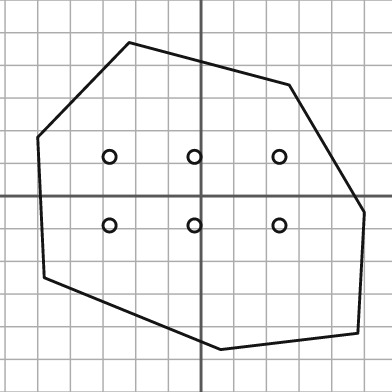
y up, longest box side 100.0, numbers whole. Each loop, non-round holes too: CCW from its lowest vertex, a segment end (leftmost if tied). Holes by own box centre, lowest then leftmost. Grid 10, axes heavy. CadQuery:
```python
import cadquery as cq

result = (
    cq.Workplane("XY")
    .moveTo(6.0, -47.0)
    .lineTo(48.0, -42.0)
    .lineTo(50.0, -5.0)
    .lineTo(27.0, 34.0)
    .lineTo(-22.0, 47.0)
    .lineTo(-50.0, 18.0)
    .lineTo(-48.0, -25.0)
    .close()
    .moveTo(-28.0, -9.0)
    .circle(2.0)
    .moveTo(-2.0, -9.0)
    .circle(2.0)
    .moveTo(24.0, -9.0)
    .circle(2.0)
    .moveTo(-28.0, 12.0)
    .circle(2.0)
    .moveTo(-2.0, 12.0)
    .circle(2.0)
    .moveTo(24.0, 12.0)
    .circle(2.0)
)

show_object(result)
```